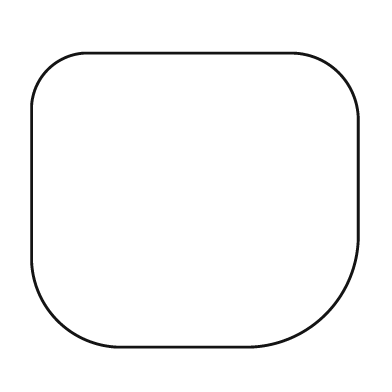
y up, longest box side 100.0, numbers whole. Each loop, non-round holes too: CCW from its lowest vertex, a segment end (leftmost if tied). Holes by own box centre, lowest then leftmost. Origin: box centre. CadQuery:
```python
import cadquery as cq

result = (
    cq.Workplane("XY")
    .moveTo(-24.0, -45.0)
    .lineTo(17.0, -45.0)
    .threePointArc((40.0, -35.0), (50.0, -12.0))
    .lineTo(50.0, 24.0)
    .threePointArc((44.0, 39.0), (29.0, 45.0))
    .lineTo(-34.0, 45.0)
    .threePointArc((-45.0, 40.0), (-50.0, 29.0))
    .lineTo(-50.0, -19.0)
    .threePointArc((-42.0, -37.0), (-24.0, -45.0))
    .close()
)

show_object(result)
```